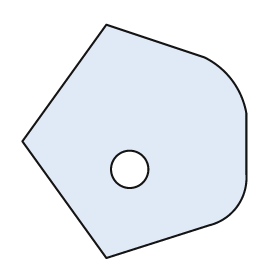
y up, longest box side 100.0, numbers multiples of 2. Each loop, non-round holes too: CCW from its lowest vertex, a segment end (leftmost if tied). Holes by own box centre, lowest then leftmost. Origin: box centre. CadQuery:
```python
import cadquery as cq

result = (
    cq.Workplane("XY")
    .moveTo(-12.0, -50.0)
    .lineTo(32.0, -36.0)
    .threePointArc((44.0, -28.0), (48.0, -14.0))
    .lineTo(48.0, 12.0)
    .threePointArc((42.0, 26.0), (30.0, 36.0))
    .lineTo(-12.0, 50.0)
    .lineTo(-48.0, 0.0)
    .close()
    .moveTo(-2.0, -12.0)
    .circle(8.0)
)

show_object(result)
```